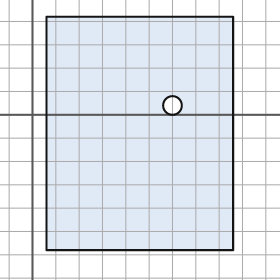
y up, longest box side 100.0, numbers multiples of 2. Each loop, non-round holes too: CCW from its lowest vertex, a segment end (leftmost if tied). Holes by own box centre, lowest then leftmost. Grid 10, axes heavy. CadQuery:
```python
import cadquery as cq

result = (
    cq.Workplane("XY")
    .moveTo(6.0, -58.0)
    .lineTo(86.0, -58.0)
    .lineTo(86.0, 42.0)
    .lineTo(6.0, 42.0)
    .close()
    .moveTo(60.0, 4.0)
    .circle(4.0)
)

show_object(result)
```